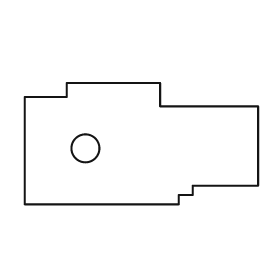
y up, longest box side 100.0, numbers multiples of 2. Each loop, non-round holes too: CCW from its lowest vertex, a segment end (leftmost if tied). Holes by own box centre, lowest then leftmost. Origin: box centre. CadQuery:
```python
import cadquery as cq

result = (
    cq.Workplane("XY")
    .moveTo(-50.0, -26.0)
    .lineTo(16.0, -26.0)
    .lineTo(16.0, -22.0)
    .lineTo(22.0, -22.0)
    .lineTo(22.0, -18.0)
    .lineTo(50.0, -18.0)
    .lineTo(50.0, 16.0)
    .lineTo(8.0, 16.0)
    .lineTo(8.0, 26.0)
    .lineTo(-32.0, 26.0)
    .lineTo(-32.0, 20.0)
    .lineTo(-50.0, 20.0)
    .close()
    .moveTo(-24.0, -2.0)
    .circle(6.0)
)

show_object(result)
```